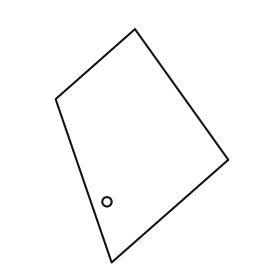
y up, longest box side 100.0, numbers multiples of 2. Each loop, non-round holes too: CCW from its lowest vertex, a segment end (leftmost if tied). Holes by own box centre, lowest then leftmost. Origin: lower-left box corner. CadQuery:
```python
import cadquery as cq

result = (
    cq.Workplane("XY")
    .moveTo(24.0, 0.0)
    .lineTo(74.0, 44.0)
    .lineTo(34.0, 100.0)
    .lineTo(0.0, 70.0)
    .close()
    .moveTo(22.0, 26.0)
    .circle(2.0)
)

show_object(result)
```